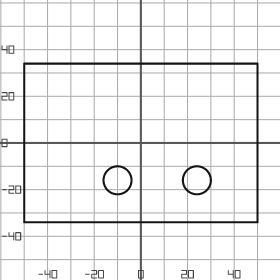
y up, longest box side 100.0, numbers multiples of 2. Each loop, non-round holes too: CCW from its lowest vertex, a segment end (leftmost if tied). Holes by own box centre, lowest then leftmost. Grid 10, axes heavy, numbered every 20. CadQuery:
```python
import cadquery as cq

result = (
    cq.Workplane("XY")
    .moveTo(-50.0, -34.0)
    .lineTo(50.0, -34.0)
    .lineTo(50.0, 34.0)
    .lineTo(-50.0, 34.0)
    .close()
    .moveTo(-10.0, -16.0)
    .circle(6.0)
    .moveTo(24.0, -16.0)
    .circle(6.0)
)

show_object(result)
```